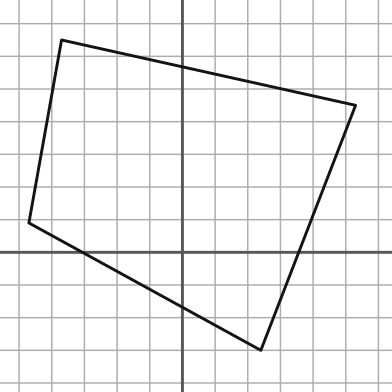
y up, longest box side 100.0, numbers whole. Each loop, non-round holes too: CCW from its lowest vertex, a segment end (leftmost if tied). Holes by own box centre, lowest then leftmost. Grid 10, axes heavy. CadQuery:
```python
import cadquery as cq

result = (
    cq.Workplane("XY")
    .moveTo(24.0, -30.0)
    .lineTo(53.0, 45.0)
    .lineTo(-37.0, 65.0)
    .lineTo(-47.0, 9.0)
    .close()
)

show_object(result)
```